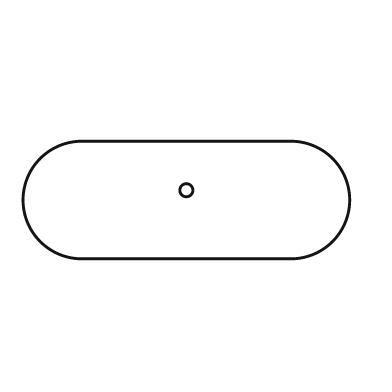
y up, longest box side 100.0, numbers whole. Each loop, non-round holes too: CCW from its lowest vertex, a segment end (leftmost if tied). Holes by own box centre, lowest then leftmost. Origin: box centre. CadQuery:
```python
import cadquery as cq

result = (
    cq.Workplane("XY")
    .moveTo(-32.0, -18.0)
    .lineTo(32.0, -18.0)
    .threePointArc((50.0, 0.0), (32.0, 18.0))
    .lineTo(-32.0, 18.0)
    .threePointArc((-50.0, 0.0), (-32.0, -18.0))
    .close()
    .moveTo(0.0, 3.0)
    .circle(2.0)
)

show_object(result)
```